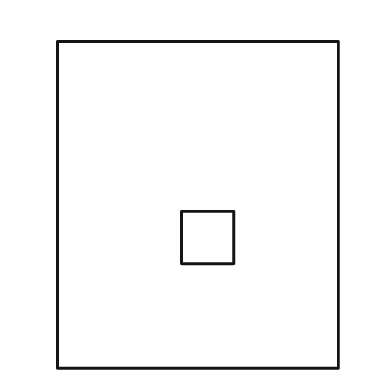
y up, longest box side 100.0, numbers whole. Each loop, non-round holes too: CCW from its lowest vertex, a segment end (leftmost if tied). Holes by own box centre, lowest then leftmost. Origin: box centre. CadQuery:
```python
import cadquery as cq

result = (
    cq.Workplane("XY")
    .moveTo(-43.0, -50.0)
    .lineTo(43.0, -50.0)
    .lineTo(43.0, 50.0)
    .lineTo(-43.0, 50.0)
    .close()
    .moveTo(-5.0, -18.0)
    .lineTo(11.0, -18.0)
    .lineTo(11.0, -2.0)
    .lineTo(-5.0, -2.0)
    .close()
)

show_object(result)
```